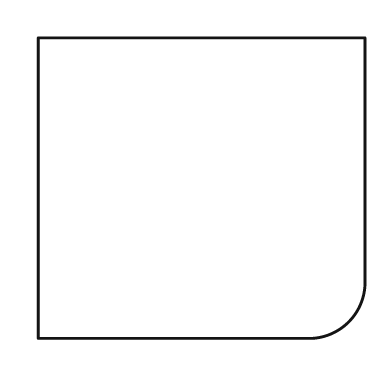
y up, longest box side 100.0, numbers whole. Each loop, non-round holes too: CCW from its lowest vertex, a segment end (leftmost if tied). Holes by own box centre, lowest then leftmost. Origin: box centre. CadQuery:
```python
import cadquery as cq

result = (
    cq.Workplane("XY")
    .moveTo(-50.0, -46.0)
    .lineTo(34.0, -46.0)
    .threePointArc((45.0, -41.0), (50.0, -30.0))
    .lineTo(50.0, 46.0)
    .lineTo(-50.0, 46.0)
    .close()
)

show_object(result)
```